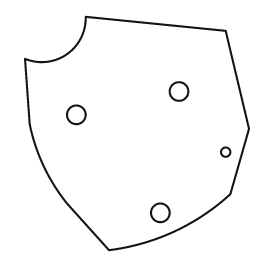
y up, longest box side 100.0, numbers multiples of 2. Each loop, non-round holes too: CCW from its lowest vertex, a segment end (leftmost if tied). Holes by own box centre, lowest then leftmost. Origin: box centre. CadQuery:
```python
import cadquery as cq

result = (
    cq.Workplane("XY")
    .moveTo(-12.0, -50.0)
    .threePointArc((16.0, -42.0), (40.0, -26.0))
    .lineTo(48.0, 2.0)
    .lineTo(38.0, 44.0)
    .lineTo(-22.0, 50.0)
    .threePointArc((-30.0, 34.0), (-48.0, 32.0))
    .lineTo(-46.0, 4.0)
    .threePointArc((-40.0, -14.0), (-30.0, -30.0))
    .close()
    .moveTo(10.0, -34.0)
    .circle(4.0)
    .moveTo(38.0, -8.0)
    .circle(2.0)
    .moveTo(-26.0, 8.0)
    .circle(4.0)
    .moveTo(18.0, 18.0)
    .circle(4.0)
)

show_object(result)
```